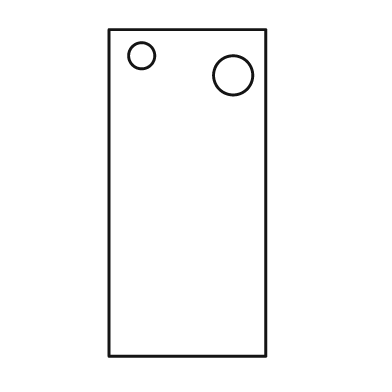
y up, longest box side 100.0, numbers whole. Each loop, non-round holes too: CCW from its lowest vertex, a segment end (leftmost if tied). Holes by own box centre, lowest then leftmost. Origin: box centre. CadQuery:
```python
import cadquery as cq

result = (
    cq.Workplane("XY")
    .moveTo(-24.0, -50.0)
    .lineTo(24.0, -50.0)
    .lineTo(24.0, 50.0)
    .lineTo(-24.0, 50.0)
    .close()
    .moveTo(14.0, 36.0)
    .circle(6.0)
    .moveTo(-14.0, 42.0)
    .circle(4.0)
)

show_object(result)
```